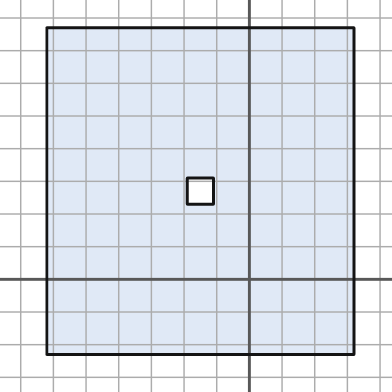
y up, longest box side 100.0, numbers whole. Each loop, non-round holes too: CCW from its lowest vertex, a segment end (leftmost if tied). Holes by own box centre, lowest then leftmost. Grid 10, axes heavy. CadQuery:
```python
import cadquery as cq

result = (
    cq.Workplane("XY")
    .moveTo(-62.0, -23.0)
    .lineTo(32.0, -23.0)
    .lineTo(32.0, 77.0)
    .lineTo(-62.0, 77.0)
    .close()
    .moveTo(-19.0, 23.0)
    .lineTo(-11.0, 23.0)
    .lineTo(-11.0, 31.0)
    .lineTo(-19.0, 31.0)
    .close()
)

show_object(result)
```